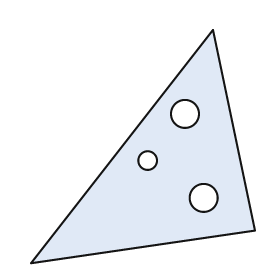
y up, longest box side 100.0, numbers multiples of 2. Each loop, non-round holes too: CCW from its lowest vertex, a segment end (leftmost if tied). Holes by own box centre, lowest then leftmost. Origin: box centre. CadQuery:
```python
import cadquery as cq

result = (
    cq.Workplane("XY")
    .moveTo(-48.0, -50.0)
    .lineTo(48.0, -36.0)
    .lineTo(30.0, 50.0)
    .close()
    .moveTo(26.0, -22.0)
    .circle(6.0)
    .moveTo(2.0, -6.0)
    .circle(4.0)
    .moveTo(18.0, 14.0)
    .circle(6.0)
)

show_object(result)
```